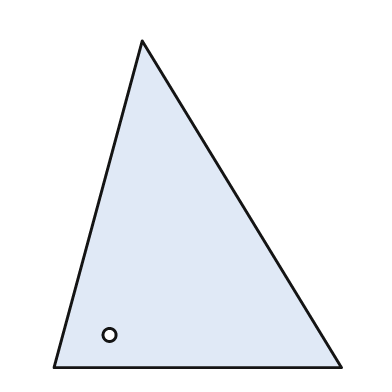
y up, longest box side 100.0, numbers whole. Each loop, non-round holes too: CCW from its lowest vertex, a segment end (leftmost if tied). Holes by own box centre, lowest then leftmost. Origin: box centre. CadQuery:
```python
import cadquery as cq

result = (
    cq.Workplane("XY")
    .moveTo(-44.0, -50.0)
    .lineTo(44.0, -50.0)
    .lineTo(-17.0, 50.0)
    .close()
    .moveTo(-27.0, -40.0)
    .circle(2.0)
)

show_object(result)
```